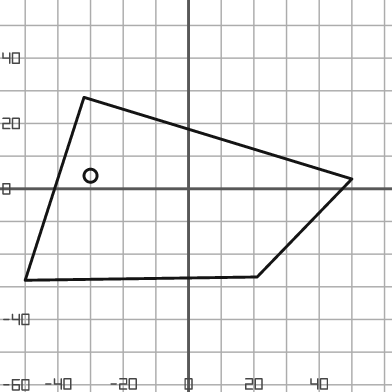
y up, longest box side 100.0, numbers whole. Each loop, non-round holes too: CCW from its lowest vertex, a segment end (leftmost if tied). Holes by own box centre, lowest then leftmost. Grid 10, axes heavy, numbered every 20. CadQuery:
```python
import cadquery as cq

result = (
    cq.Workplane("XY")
    .moveTo(-50.0, -28.0)
    .lineTo(21.0, -27.0)
    .lineTo(50.0, 3.0)
    .lineTo(-32.0, 28.0)
    .close()
    .moveTo(-30.0, 4.0)
    .circle(2.0)
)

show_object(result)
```